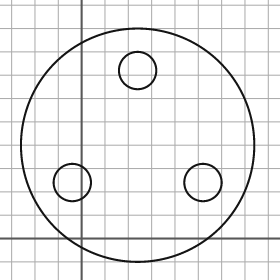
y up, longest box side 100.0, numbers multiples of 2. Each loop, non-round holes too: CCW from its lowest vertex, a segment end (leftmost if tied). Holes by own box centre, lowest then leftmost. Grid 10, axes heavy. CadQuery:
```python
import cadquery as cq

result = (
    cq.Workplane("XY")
    .moveTo(24.0, 40.0)
    .circle(50.0)
    .moveTo(-4.0, 24.0)
    .circle(8.0)
    .moveTo(52.0, 24.0)
    .circle(8.0)
    .moveTo(24.0, 72.0)
    .circle(8.0)
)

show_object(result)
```